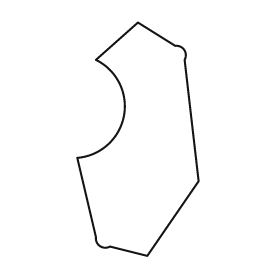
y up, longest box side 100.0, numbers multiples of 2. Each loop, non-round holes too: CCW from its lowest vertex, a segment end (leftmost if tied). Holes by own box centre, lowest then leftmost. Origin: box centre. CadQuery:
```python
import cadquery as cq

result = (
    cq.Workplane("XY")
    .moveTo(4.0, -50.0)
    .lineTo(26.0, -18.0)
    .lineTo(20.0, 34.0)
    .threePointArc((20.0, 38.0), (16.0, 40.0))
    .lineTo(0.0, 50.0)
    .lineTo(-18.0, 34.0)
    .threePointArc((-6.0, 10.0), (-26.0, -8.0))
    .lineTo(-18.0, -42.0)
    .threePointArc((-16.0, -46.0), (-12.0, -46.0))
    .close()
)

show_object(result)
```